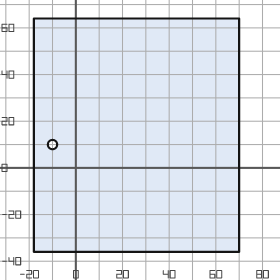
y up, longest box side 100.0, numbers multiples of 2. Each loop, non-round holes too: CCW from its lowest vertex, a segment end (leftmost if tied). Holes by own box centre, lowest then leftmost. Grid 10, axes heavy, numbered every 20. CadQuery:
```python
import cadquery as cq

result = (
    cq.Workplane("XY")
    .moveTo(-18.0, -36.0)
    .lineTo(70.0, -36.0)
    .lineTo(70.0, 64.0)
    .lineTo(-18.0, 64.0)
    .close()
    .moveTo(-10.0, 10.0)
    .circle(2.0)
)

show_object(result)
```